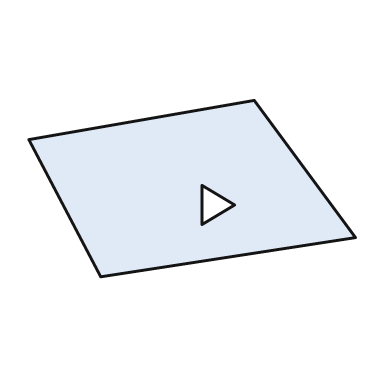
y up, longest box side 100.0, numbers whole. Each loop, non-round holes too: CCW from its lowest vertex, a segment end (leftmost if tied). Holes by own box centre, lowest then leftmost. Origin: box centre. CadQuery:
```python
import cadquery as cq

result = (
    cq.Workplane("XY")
    .moveTo(-28.0, -27.0)
    .lineTo(50.0, -15.0)
    .lineTo(19.0, 27.0)
    .lineTo(-50.0, 15.0)
    .close()
    .moveTo(3.0, -11.0)
    .lineTo(13.0, -5.0)
    .lineTo(3.0, 1.0)
    .close()
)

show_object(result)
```